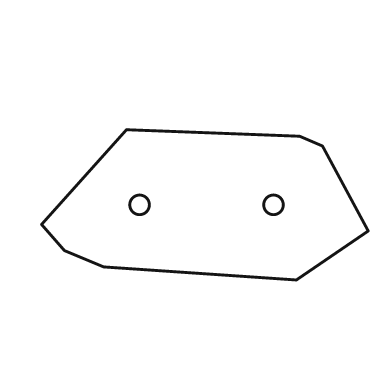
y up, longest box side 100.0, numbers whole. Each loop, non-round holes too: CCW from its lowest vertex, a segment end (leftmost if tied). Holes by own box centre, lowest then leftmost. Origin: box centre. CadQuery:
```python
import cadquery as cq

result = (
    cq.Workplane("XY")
    .moveTo(28.0, -23.0)
    .lineTo(50.0, -8.0)
    .lineTo(36.0, 18.0)
    .lineTo(29.0, 21.0)
    .lineTo(-24.0, 23.0)
    .lineTo(-50.0, -6.0)
    .lineTo(-43.0, -14.0)
    .lineTo(-31.0, -19.0)
    .close()
    .moveTo(-20.0, 0.0)
    .circle(3.0)
    .moveTo(21.0, 0.0)
    .circle(3.0)
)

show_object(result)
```